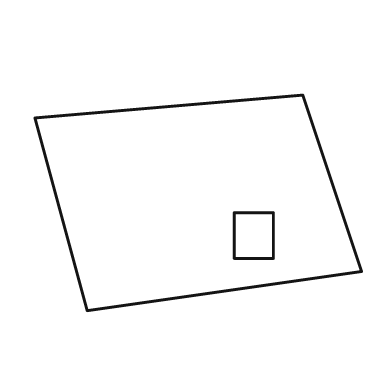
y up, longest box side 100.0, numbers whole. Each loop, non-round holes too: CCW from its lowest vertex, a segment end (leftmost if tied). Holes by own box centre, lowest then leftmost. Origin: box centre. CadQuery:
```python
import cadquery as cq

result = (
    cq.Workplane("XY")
    .moveTo(-34.0, -33.0)
    .lineTo(50.0, -21.0)
    .lineTo(32.0, 33.0)
    .lineTo(-50.0, 26.0)
    .close()
    .moveTo(11.0, -17.0)
    .lineTo(23.0, -17.0)
    .lineTo(23.0, -3.0)
    .lineTo(11.0, -3.0)
    .close()
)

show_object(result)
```